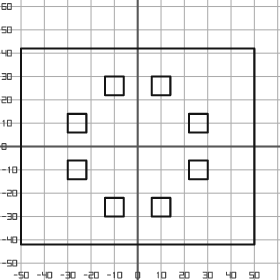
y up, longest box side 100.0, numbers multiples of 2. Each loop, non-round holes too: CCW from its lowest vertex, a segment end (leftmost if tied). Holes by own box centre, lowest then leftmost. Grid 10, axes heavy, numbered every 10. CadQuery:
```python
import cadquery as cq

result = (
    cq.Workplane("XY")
    .moveTo(-50.0, -42.0)
    .lineTo(50.0, -42.0)
    .lineTo(50.0, 42.0)
    .lineTo(-50.0, 42.0)
    .close()
    .moveTo(-14.0, -30.0)
    .lineTo(-6.0, -30.0)
    .lineTo(-6.0, -22.0)
    .lineTo(-14.0, -22.0)
    .close()
    .moveTo(6.0, -30.0)
    .lineTo(14.0, -30.0)
    .lineTo(14.0, -22.0)
    .lineTo(6.0, -22.0)
    .close()
    .moveTo(-30.0, -14.0)
    .lineTo(-22.0, -14.0)
    .lineTo(-22.0, -6.0)
    .lineTo(-30.0, -6.0)
    .close()
    .moveTo(22.0, -14.0)
    .lineTo(30.0, -14.0)
    .lineTo(30.0, -6.0)
    .lineTo(22.0, -6.0)
    .close()
    .moveTo(-30.0, 6.0)
    .lineTo(-22.0, 6.0)
    .lineTo(-22.0, 14.0)
    .lineTo(-30.0, 14.0)
    .close()
    .moveTo(22.0, 6.0)
    .lineTo(30.0, 6.0)
    .lineTo(30.0, 14.0)
    .lineTo(22.0, 14.0)
    .close()
    .moveTo(-14.0, 22.0)
    .lineTo(-6.0, 22.0)
    .lineTo(-6.0, 30.0)
    .lineTo(-14.0, 30.0)
    .close()
    .moveTo(6.0, 22.0)
    .lineTo(14.0, 22.0)
    .lineTo(14.0, 30.0)
    .lineTo(6.0, 30.0)
    .close()
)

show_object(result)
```